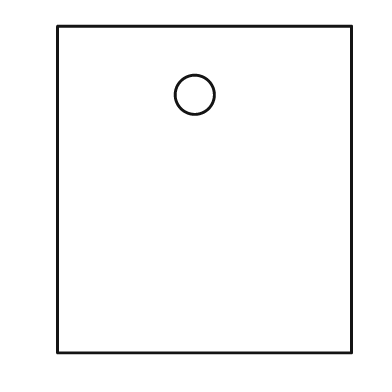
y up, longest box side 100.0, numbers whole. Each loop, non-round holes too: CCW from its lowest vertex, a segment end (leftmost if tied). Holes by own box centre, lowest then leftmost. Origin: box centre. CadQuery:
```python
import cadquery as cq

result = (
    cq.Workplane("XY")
    .moveTo(-45.0, -50.0)
    .lineTo(45.0, -50.0)
    .lineTo(45.0, 50.0)
    .lineTo(-45.0, 50.0)
    .close()
    .moveTo(-3.0, 29.0)
    .circle(6.0)
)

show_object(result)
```